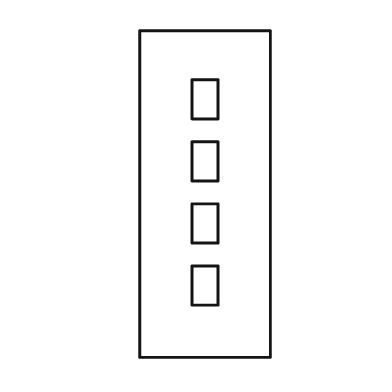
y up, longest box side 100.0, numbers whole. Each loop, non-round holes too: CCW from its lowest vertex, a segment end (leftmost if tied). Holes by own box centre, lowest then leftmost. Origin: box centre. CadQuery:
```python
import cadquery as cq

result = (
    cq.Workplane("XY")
    .moveTo(-20.0, -50.0)
    .lineTo(20.0, -50.0)
    .lineTo(20.0, 50.0)
    .lineTo(-20.0, 50.0)
    .close()
    .moveTo(-4.0, -34.0)
    .lineTo(4.0, -34.0)
    .lineTo(4.0, -22.0)
    .lineTo(-4.0, -22.0)
    .close()
    .moveTo(-4.0, -15.0)
    .lineTo(4.0, -15.0)
    .lineTo(4.0, -3.0)
    .lineTo(-4.0, -3.0)
    .close()
    .moveTo(-4.0, 4.0)
    .lineTo(4.0, 4.0)
    .lineTo(4.0, 16.0)
    .lineTo(-4.0, 16.0)
    .close()
    .moveTo(-4.0, 23.0)
    .lineTo(4.0, 23.0)
    .lineTo(4.0, 35.0)
    .lineTo(-4.0, 35.0)
    .close()
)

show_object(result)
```